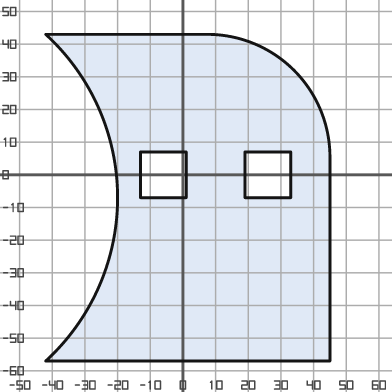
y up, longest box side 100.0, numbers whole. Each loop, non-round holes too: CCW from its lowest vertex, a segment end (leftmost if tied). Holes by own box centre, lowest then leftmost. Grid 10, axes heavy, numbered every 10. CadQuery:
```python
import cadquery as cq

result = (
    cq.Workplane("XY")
    .moveTo(-42.0, -57.0)
    .lineTo(45.0, -57.0)
    .lineTo(45.0, 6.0)
    .threePointArc((34.0, 32.0), (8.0, 43.0))
    .lineTo(-42.0, 43.0)
    .threePointArc((-20.0, -7.0), (-42.0, -57.0))
    .close()
    .moveTo(-13.0, -7.0)
    .lineTo(1.0, -7.0)
    .lineTo(1.0, 7.0)
    .lineTo(-13.0, 7.0)
    .close()
    .moveTo(19.0, -7.0)
    .lineTo(33.0, -7.0)
    .lineTo(33.0, 7.0)
    .lineTo(19.0, 7.0)
    .close()
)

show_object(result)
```